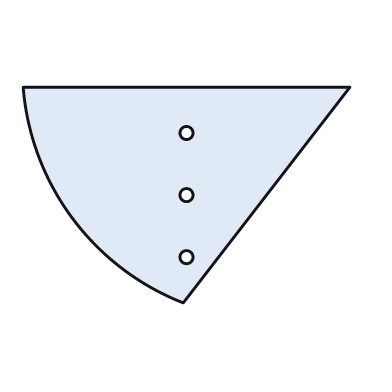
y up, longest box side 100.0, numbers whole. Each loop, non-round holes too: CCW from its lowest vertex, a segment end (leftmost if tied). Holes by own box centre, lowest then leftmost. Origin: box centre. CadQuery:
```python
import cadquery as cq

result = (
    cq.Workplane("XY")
    .moveTo(-1.0, -33.0)
    .lineTo(50.0, 33.0)
    .lineTo(-50.0, 33.0)
    .threePointArc((-35.0, -7.0), (-1.0, -33.0))
    .close()
    .moveTo(0.0, -19.0)
    .circle(2.0)
    .moveTo(0.0, 0.0)
    .circle(2.0)
    .moveTo(0.0, 19.0)
    .circle(2.0)
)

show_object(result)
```